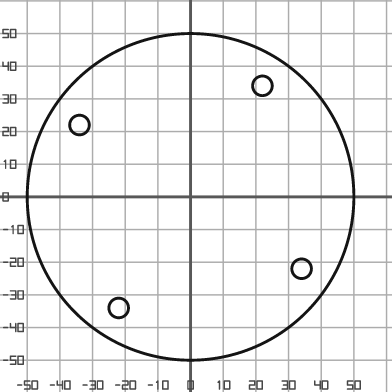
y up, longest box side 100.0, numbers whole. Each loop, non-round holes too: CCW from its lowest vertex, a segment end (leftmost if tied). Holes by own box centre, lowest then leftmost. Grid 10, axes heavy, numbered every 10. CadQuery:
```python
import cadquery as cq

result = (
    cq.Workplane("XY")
    .moveTo(0.0, 0.0)
    .circle(50.0)
    .moveTo(-22.0, -34.0)
    .circle(3.0)
    .moveTo(34.0, -22.0)
    .circle(3.0)
    .moveTo(-34.0, 22.0)
    .circle(3.0)
    .moveTo(22.0, 34.0)
    .circle(3.0)
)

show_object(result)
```